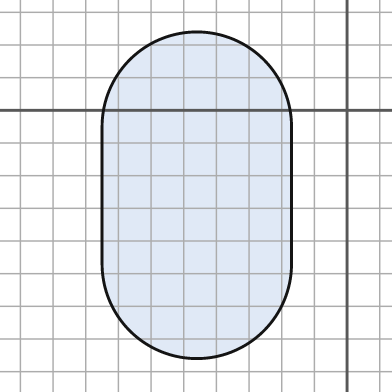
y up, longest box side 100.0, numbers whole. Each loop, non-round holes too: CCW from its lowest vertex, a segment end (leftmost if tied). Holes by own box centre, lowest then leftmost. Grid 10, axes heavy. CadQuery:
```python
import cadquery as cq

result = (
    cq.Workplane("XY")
    .moveTo(-75.0, -47.0)
    .threePointArc((-46.0, -76.0), (-17.0, -47.0))
    .lineTo(-17.0, -5.0)
    .threePointArc((-46.0, 24.0), (-75.0, -5.0))
    .close()
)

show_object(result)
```